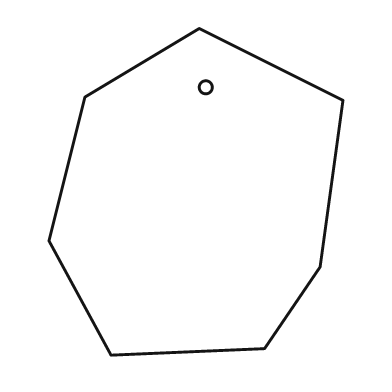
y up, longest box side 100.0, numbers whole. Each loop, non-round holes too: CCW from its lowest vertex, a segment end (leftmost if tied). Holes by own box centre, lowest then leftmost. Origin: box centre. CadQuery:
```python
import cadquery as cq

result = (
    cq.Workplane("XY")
    .moveTo(-26.0, -50.0)
    .lineTo(21.0, -48.0)
    .lineTo(38.0, -23.0)
    .lineTo(45.0, 28.0)
    .lineTo(1.0, 50.0)
    .lineTo(-34.0, 29.0)
    .lineTo(-45.0, -15.0)
    .close()
    .moveTo(3.0, 32.0)
    .circle(2.0)
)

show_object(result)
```